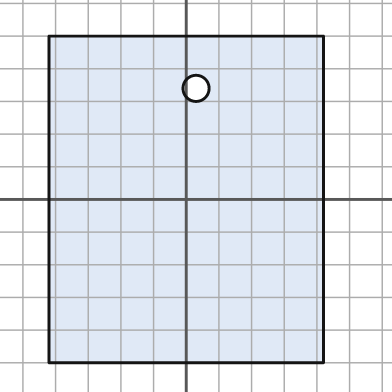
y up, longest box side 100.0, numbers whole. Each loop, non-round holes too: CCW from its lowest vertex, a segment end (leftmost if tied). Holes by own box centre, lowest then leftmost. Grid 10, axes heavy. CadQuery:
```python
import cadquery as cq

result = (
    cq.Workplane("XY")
    .moveTo(-42.0, -50.0)
    .lineTo(42.0, -50.0)
    .lineTo(42.0, 50.0)
    .lineTo(-42.0, 50.0)
    .close()
    .moveTo(3.0, 34.0)
    .circle(4.0)
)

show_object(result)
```